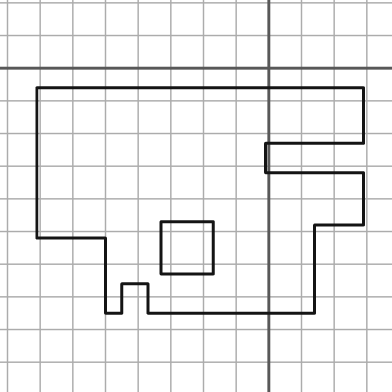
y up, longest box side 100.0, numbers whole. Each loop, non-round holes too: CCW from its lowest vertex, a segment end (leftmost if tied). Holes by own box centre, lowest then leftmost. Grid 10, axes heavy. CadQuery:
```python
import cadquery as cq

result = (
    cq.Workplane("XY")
    .moveTo(-50.0, -75.0)
    .lineTo(-45.0, -75.0)
    .lineTo(-45.0, -66.0)
    .lineTo(-37.0, -66.0)
    .lineTo(-37.0, -75.0)
    .lineTo(14.0, -75.0)
    .lineTo(14.0, -48.0)
    .lineTo(29.0, -48.0)
    .lineTo(29.0, -32.0)
    .lineTo(-1.0, -32.0)
    .lineTo(-1.0, -23.0)
    .lineTo(29.0, -23.0)
    .lineTo(29.0, -6.0)
    .lineTo(-71.0, -6.0)
    .lineTo(-71.0, -52.0)
    .lineTo(-50.0, -52.0)
    .close()
    .moveTo(-33.0, -63.0)
    .lineTo(-17.0, -63.0)
    .lineTo(-17.0, -47.0)
    .lineTo(-33.0, -47.0)
    .close()
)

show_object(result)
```